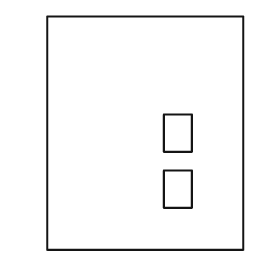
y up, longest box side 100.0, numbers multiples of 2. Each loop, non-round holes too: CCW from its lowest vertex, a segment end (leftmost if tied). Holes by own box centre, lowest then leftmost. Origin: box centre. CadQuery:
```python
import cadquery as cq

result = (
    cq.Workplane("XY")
    .moveTo(-42.0, -50.0)
    .lineTo(42.0, -50.0)
    .lineTo(42.0, 50.0)
    .lineTo(-42.0, 50.0)
    .close()
    .moveTo(8.0, -32.0)
    .lineTo(20.0, -32.0)
    .lineTo(20.0, -16.0)
    .lineTo(8.0, -16.0)
    .close()
    .moveTo(8.0, -8.0)
    .lineTo(20.0, -8.0)
    .lineTo(20.0, 8.0)
    .lineTo(8.0, 8.0)
    .close()
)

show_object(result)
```